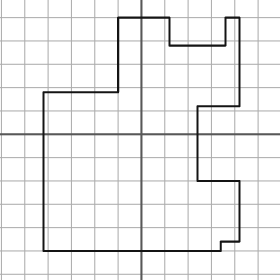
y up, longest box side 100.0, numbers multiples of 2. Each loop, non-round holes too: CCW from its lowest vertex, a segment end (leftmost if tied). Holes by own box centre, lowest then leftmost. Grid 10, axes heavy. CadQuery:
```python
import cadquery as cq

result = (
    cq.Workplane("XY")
    .moveTo(-42.0, -50.0)
    .lineTo(34.0, -50.0)
    .lineTo(34.0, -46.0)
    .lineTo(42.0, -46.0)
    .lineTo(42.0, -20.0)
    .lineTo(24.0, -20.0)
    .lineTo(24.0, 12.0)
    .lineTo(42.0, 12.0)
    .lineTo(42.0, 50.0)
    .lineTo(36.0, 50.0)
    .lineTo(36.0, 38.0)
    .lineTo(12.0, 38.0)
    .lineTo(12.0, 50.0)
    .lineTo(-10.0, 50.0)
    .lineTo(-10.0, 18.0)
    .lineTo(-42.0, 18.0)
    .close()
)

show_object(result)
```